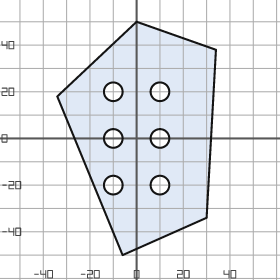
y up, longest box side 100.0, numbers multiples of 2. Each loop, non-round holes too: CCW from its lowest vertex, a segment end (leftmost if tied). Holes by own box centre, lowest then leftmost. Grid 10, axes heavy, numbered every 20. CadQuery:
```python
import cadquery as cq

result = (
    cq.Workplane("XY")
    .moveTo(-6.0, -50.0)
    .lineTo(30.0, -34.0)
    .lineTo(34.0, 38.0)
    .lineTo(0.0, 50.0)
    .lineTo(-34.0, 18.0)
    .close()
    .moveTo(-10.0, -20.0)
    .circle(4.0)
    .moveTo(10.0, -20.0)
    .circle(4.0)
    .moveTo(-10.0, 0.0)
    .circle(4.0)
    .moveTo(10.0, 0.0)
    .circle(4.0)
    .moveTo(-10.0, 20.0)
    .circle(4.0)
    .moveTo(10.0, 20.0)
    .circle(4.0)
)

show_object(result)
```